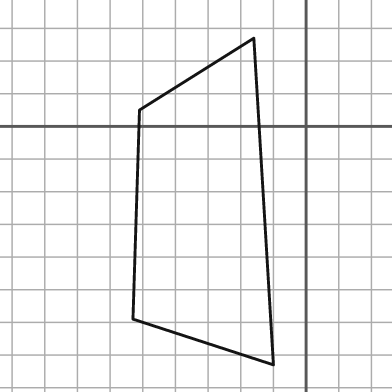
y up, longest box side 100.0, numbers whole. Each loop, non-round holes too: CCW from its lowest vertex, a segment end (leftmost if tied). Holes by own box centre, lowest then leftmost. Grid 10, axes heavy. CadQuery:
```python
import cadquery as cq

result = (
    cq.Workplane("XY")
    .moveTo(-10.0, -73.0)
    .lineTo(-16.0, 27.0)
    .lineTo(-51.0, 5.0)
    .lineTo(-53.0, -59.0)
    .close()
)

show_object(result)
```